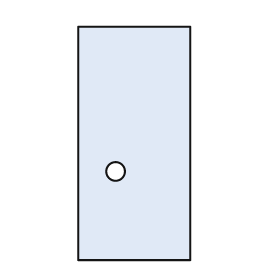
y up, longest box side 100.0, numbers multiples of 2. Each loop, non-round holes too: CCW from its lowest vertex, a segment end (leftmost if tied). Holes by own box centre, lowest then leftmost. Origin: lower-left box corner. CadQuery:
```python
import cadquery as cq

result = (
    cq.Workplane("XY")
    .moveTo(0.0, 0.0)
    .lineTo(48.0, 0.0)
    .lineTo(48.0, 100.0)
    .lineTo(0.0, 100.0)
    .close()
    .moveTo(16.0, 38.0)
    .circle(4.0)
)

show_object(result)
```